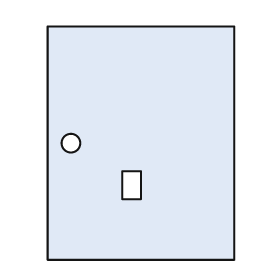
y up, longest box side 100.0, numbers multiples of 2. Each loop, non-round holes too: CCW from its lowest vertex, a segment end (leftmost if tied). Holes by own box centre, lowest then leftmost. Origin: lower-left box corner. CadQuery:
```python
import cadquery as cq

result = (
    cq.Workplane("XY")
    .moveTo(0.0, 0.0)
    .lineTo(80.0, 0.0)
    .lineTo(80.0, 100.0)
    .lineTo(0.0, 100.0)
    .close()
    .moveTo(32.0, 26.0)
    .lineTo(40.0, 26.0)
    .lineTo(40.0, 38.0)
    .lineTo(32.0, 38.0)
    .close()
    .moveTo(10.0, 50.0)
    .circle(4.0)
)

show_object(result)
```